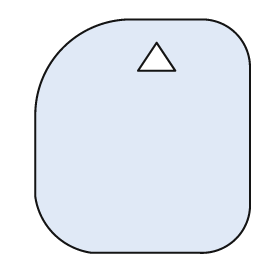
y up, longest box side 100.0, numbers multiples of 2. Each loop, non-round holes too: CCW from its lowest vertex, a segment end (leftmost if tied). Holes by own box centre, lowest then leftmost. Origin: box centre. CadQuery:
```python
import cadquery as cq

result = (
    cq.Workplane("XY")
    .moveTo(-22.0, -50.0)
    .lineTo(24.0, -50.0)
    .threePointArc((40.0, -44.0), (46.0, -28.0))
    .lineTo(46.0, 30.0)
    .threePointArc((40.0, 44.0), (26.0, 50.0))
    .lineTo(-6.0, 50.0)
    .threePointArc((-34.0, 38.0), (-46.0, 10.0))
    .lineTo(-46.0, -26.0)
    .threePointArc((-38.0, -42.0), (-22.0, -50.0))
    .close()
    .moveTo(-2.0, 28.0)
    .lineTo(14.0, 28.0)
    .lineTo(6.0, 40.0)
    .close()
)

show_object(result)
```